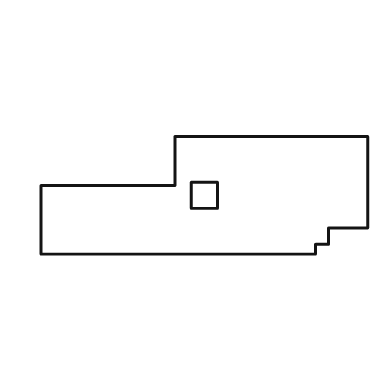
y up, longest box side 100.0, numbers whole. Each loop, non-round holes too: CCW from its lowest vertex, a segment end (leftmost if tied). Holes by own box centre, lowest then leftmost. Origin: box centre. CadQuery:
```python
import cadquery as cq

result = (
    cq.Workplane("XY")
    .moveTo(-50.0, -18.0)
    .lineTo(34.0, -18.0)
    .lineTo(34.0, -15.0)
    .lineTo(38.0, -15.0)
    .lineTo(38.0, -10.0)
    .lineTo(50.0, -10.0)
    .lineTo(50.0, 18.0)
    .lineTo(-9.0, 18.0)
    .lineTo(-9.0, 3.0)
    .lineTo(-50.0, 3.0)
    .close()
    .moveTo(-4.0, -4.0)
    .lineTo(4.0, -4.0)
    .lineTo(4.0, 4.0)
    .lineTo(-4.0, 4.0)
    .close()
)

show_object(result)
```